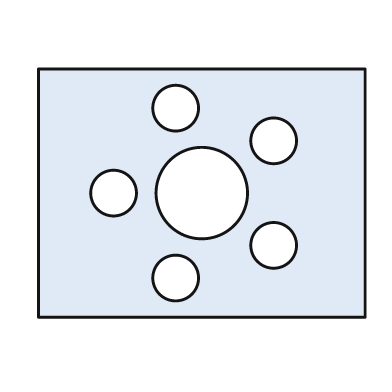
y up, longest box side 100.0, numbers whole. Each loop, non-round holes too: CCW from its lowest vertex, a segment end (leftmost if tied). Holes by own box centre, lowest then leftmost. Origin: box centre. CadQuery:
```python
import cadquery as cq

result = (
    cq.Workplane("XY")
    .moveTo(-50.0, -38.0)
    .lineTo(50.0, -38.0)
    .lineTo(50.0, 38.0)
    .lineTo(-50.0, 38.0)
    .close()
    .moveTo(-8.0, -26.0)
    .circle(7.0)
    .moveTo(22.0, -16.0)
    .circle(7.0)
    .moveTo(-27.0, 0.0)
    .circle(7.0)
    .moveTo(0.0, 0.0)
    .circle(14.0)
    .moveTo(22.0, 16.0)
    .circle(7.0)
    .moveTo(-8.0, 26.0)
    .circle(7.0)
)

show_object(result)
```